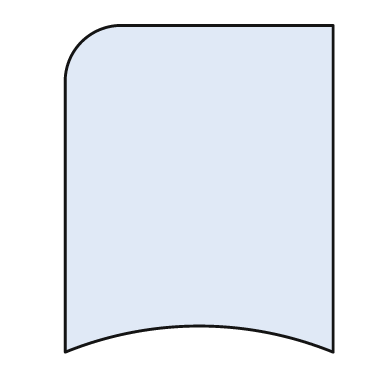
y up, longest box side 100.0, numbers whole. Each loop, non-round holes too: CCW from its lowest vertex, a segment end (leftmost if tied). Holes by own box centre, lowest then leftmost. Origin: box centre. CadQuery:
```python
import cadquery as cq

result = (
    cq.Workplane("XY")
    .moveTo(-41.0, -50.0)
    .threePointArc((0.0, -42.0), (41.0, -50.0))
    .lineTo(41.0, 50.0)
    .lineTo(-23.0, 50.0)
    .threePointArc((-36.0, 45.0), (-41.0, 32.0))
    .close()
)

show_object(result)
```